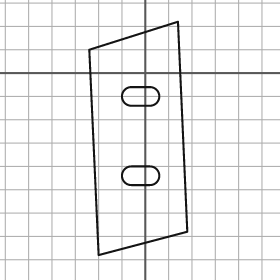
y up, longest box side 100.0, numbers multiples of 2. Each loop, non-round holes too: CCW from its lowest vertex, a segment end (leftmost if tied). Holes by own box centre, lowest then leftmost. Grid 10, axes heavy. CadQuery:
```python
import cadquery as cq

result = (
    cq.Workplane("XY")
    .moveTo(-20.0, -78.0)
    .lineTo(18.0, -68.0)
    .lineTo(14.0, 22.0)
    .lineTo(-24.0, 10.0)
    .close()
    .moveTo(-6.0, -48.0)
    .lineTo(2.0, -48.0)
    .threePointArc((6.0, -44.0), (2.0, -40.0))
    .lineTo(-6.0, -40.0)
    .threePointArc((-10.0, -44.0), (-6.0, -48.0))
    .close()
    .moveTo(-6.0, -14.0)
    .lineTo(2.0, -14.0)
    .threePointArc((6.0, -10.0), (2.0, -6.0))
    .lineTo(-6.0, -6.0)
    .threePointArc((-10.0, -10.0), (-6.0, -14.0))
    .close()
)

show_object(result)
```